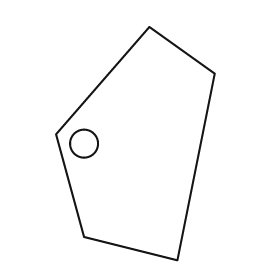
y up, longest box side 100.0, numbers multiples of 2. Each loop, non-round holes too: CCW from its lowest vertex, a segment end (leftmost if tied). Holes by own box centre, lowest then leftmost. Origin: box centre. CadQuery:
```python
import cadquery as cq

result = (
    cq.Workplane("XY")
    .moveTo(18.0, -50.0)
    .lineTo(34.0, 30.0)
    .lineTo(6.0, 50.0)
    .lineTo(-34.0, 4.0)
    .lineTo(-22.0, -40.0)
    .close()
    .moveTo(-22.0, 0.0)
    .circle(6.0)
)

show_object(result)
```